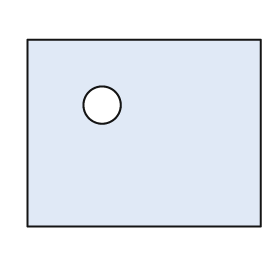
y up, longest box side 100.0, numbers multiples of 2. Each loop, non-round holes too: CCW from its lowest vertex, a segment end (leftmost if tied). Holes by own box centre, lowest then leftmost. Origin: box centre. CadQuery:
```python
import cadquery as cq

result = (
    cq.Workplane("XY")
    .moveTo(-50.0, -40.0)
    .lineTo(50.0, -40.0)
    .lineTo(50.0, 40.0)
    .lineTo(-50.0, 40.0)
    .close()
    .moveTo(-18.0, 12.0)
    .circle(8.0)
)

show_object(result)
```